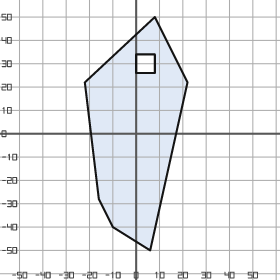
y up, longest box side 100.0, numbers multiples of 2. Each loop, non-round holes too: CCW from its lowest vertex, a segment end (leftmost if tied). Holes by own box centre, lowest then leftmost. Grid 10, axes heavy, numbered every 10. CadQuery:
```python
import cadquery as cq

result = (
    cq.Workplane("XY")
    .moveTo(6.0, -50.0)
    .lineTo(22.0, 22.0)
    .lineTo(8.0, 50.0)
    .lineTo(-22.0, 22.0)
    .lineTo(-16.0, -28.0)
    .lineTo(-10.0, -40.0)
    .close()
    .moveTo(0.0, 26.0)
    .lineTo(8.0, 26.0)
    .lineTo(8.0, 34.0)
    .lineTo(0.0, 34.0)
    .close()
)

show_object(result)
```